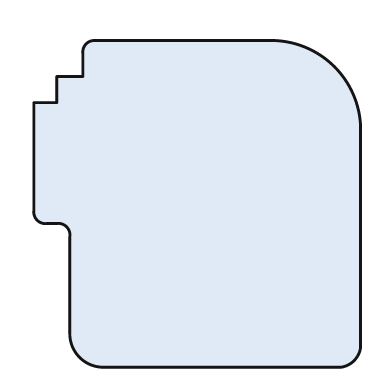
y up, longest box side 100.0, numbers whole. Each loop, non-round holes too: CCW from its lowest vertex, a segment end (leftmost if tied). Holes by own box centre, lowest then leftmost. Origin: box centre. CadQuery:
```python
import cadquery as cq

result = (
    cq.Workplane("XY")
    .moveTo(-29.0, -50.0)
    .lineTo(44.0, -50.0)
    .threePointArc((48.0, -48.0), (50.0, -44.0))
    .lineTo(50.0, 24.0)
    .threePointArc((42.0, 42.0), (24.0, 50.0))
    .lineTo(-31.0, 50.0)
    .threePointArc((-34.0, 49.0), (-35.0, 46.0))
    .lineTo(-35.0, 39.0)
    .lineTo(-43.0, 39.0)
    .lineTo(-43.0, 31.0)
    .lineTo(-50.0, 31.0)
    .lineTo(-50.0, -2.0)
    .threePointArc((-49.0, -5.0), (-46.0, -6.0))
    .lineTo(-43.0, -6.0)
    .threePointArc((-40.0, -7.0), (-39.0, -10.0))
    .lineTo(-39.0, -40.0)
    .threePointArc((-36.0, -47.0), (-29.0, -50.0))
    .close()
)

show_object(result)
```